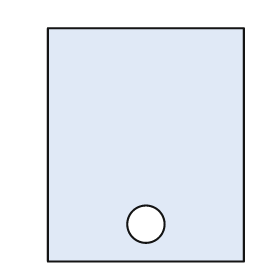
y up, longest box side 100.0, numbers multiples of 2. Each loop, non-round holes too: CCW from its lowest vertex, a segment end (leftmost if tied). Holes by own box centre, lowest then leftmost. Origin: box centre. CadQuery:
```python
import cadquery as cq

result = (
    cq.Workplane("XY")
    .moveTo(-42.0, -50.0)
    .lineTo(42.0, -50.0)
    .lineTo(42.0, 50.0)
    .lineTo(-42.0, 50.0)
    .close()
    .moveTo(0.0, -34.0)
    .circle(8.0)
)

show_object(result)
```